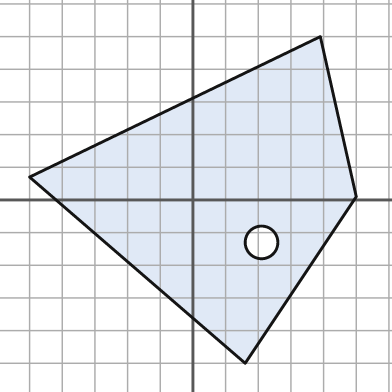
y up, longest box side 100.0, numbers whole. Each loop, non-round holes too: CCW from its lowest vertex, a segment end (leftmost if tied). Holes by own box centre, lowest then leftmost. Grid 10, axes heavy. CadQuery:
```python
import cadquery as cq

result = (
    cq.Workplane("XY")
    .moveTo(16.0, -50.0)
    .lineTo(50.0, 1.0)
    .lineTo(39.0, 50.0)
    .lineTo(-50.0, 7.0)
    .close()
    .moveTo(21.0, -13.0)
    .circle(5.0)
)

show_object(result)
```